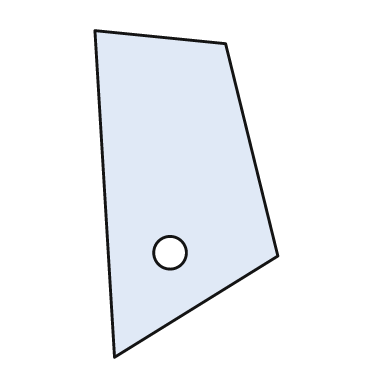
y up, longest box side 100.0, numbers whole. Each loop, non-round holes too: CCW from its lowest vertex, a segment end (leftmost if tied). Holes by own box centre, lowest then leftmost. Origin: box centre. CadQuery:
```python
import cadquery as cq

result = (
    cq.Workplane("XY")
    .moveTo(-22.0, -50.0)
    .lineTo(28.0, -19.0)
    .lineTo(12.0, 46.0)
    .lineTo(-28.0, 50.0)
    .close()
    .moveTo(-5.0, -18.0)
    .circle(5.0)
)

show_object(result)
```